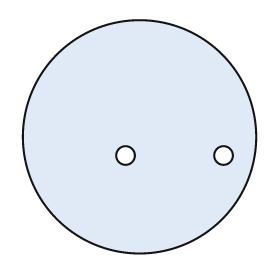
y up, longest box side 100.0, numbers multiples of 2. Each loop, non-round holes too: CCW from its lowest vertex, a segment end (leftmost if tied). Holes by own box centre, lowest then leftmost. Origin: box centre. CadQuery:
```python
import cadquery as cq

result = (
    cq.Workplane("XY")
    .moveTo(0.0, 0.0)
    .circle(50.0)
    .moveTo(-6.0, -8.0)
    .circle(4.0)
    .moveTo(36.0, -8.0)
    .circle(4.0)
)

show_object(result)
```